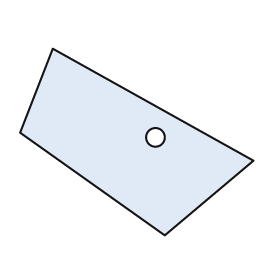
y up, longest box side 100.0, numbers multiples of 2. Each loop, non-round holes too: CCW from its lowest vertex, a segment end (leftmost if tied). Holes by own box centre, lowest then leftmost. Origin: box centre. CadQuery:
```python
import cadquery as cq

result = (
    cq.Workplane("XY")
    .moveTo(12.0, -40.0)
    .lineTo(50.0, -8.0)
    .lineTo(-36.0, 40.0)
    .lineTo(-50.0, 4.0)
    .close()
    .moveTo(8.0, 2.0)
    .circle(4.0)
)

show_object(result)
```